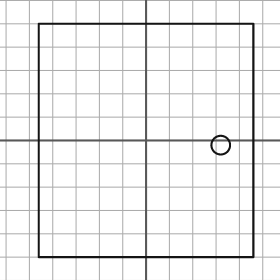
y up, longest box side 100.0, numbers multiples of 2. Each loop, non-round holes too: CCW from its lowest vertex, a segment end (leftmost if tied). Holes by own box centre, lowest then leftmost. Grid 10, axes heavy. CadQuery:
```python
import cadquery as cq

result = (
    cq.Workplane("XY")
    .moveTo(-46.0, -50.0)
    .lineTo(46.0, -50.0)
    .lineTo(46.0, 50.0)
    .lineTo(-46.0, 50.0)
    .close()
    .moveTo(32.0, -2.0)
    .circle(4.0)
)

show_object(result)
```